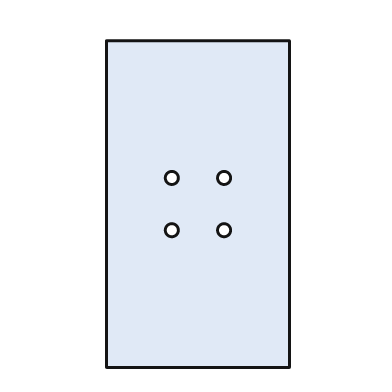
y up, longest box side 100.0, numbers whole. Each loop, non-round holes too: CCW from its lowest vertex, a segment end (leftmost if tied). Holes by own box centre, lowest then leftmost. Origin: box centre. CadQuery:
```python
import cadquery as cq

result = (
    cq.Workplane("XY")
    .moveTo(-28.0, -50.0)
    .lineTo(28.0, -50.0)
    .lineTo(28.0, 50.0)
    .lineTo(-28.0, 50.0)
    .close()
    .moveTo(-8.0, -8.0)
    .circle(2.0)
    .moveTo(8.0, -8.0)
    .circle(2.0)
    .moveTo(-8.0, 8.0)
    .circle(2.0)
    .moveTo(8.0, 8.0)
    .circle(2.0)
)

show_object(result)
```